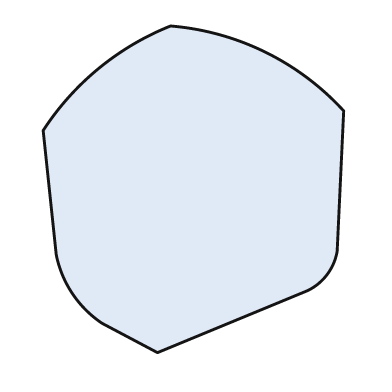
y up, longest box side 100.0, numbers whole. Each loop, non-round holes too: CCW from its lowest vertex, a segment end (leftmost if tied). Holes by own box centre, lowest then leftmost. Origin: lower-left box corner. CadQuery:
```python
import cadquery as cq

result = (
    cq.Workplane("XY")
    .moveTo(35.0, 0.0)
    .lineTo(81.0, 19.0)
    .threePointArc((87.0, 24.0), (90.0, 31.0))
    .lineTo(92.0, 74.0)
    .threePointArc((68.0, 92.0), (39.0, 100.0))
    .threePointArc((17.0, 87.0), (0.0, 68.0))
    .lineTo(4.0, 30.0)
    .threePointArc((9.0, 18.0), (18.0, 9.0))
    .close()
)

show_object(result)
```